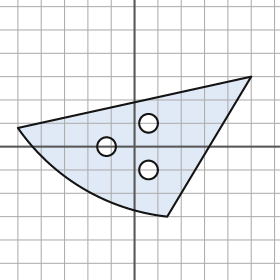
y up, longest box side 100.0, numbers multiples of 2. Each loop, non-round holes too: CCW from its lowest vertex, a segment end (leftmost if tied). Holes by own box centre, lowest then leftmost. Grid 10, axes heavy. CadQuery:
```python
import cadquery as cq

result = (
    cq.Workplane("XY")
    .moveTo(14.0, -30.0)
    .lineTo(50.0, 30.0)
    .lineTo(-50.0, 8.0)
    .threePointArc((-22.0, -18.0), (14.0, -30.0))
    .close()
    .moveTo(6.0, -10.0)
    .circle(4.0)
    .moveTo(-12.0, 0.0)
    .circle(4.0)
    .moveTo(6.0, 10.0)
    .circle(4.0)
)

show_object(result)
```